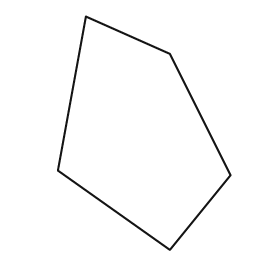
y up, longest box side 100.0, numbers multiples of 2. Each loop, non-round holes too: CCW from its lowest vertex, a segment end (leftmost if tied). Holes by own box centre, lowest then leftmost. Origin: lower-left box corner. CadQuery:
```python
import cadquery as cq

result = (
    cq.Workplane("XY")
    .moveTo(48.0, 0.0)
    .lineTo(74.0, 32.0)
    .lineTo(48.0, 84.0)
    .lineTo(12.0, 100.0)
    .lineTo(0.0, 34.0)
    .close()
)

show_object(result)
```